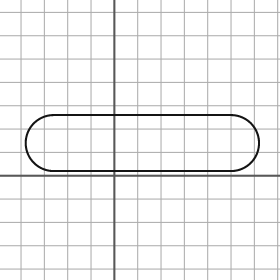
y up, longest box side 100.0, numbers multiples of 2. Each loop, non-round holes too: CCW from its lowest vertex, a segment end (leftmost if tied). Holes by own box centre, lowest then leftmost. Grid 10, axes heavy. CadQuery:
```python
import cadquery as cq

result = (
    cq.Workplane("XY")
    .moveTo(-26.0, 2.0)
    .lineTo(50.0, 2.0)
    .threePointArc((62.0, 14.0), (50.0, 26.0))
    .lineTo(-26.0, 26.0)
    .threePointArc((-38.0, 14.0), (-26.0, 2.0))
    .close()
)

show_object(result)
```